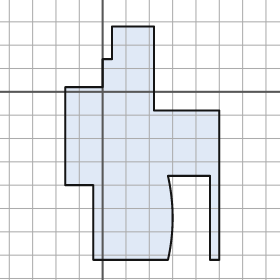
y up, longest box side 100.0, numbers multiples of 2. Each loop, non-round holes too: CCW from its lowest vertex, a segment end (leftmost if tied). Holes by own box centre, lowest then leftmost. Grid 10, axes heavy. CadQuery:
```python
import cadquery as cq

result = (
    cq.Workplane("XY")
    .moveTo(-4.0, -72.0)
    .lineTo(28.0, -72.0)
    .threePointArc((30.0, -54.0), (28.0, -36.0))
    .lineTo(46.0, -36.0)
    .lineTo(46.0, -72.0)
    .lineTo(50.0, -72.0)
    .lineTo(50.0, -8.0)
    .lineTo(22.0, -8.0)
    .lineTo(22.0, 28.0)
    .lineTo(4.0, 28.0)
    .lineTo(4.0, 14.0)
    .lineTo(0.0, 14.0)
    .lineTo(0.0, 2.0)
    .lineTo(-16.0, 2.0)
    .lineTo(-16.0, -40.0)
    .lineTo(-4.0, -40.0)
    .close()
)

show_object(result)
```